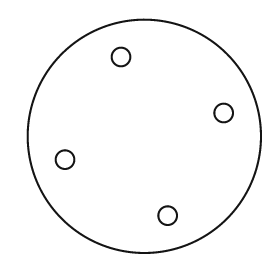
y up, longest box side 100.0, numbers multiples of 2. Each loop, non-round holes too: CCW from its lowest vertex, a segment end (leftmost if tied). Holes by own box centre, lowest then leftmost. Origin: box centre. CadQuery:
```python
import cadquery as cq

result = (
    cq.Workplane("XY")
    .moveTo(0.0, 0.0)
    .circle(50.0)
    .moveTo(10.0, -34.0)
    .circle(4.0)
    .moveTo(-34.0, -10.0)
    .circle(4.0)
    .moveTo(34.0, 10.0)
    .circle(4.0)
    .moveTo(-10.0, 34.0)
    .circle(4.0)
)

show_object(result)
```